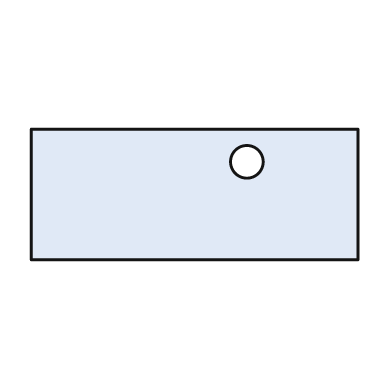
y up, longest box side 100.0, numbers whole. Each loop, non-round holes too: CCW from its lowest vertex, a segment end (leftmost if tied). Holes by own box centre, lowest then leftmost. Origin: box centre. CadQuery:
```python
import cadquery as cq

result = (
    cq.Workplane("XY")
    .moveTo(-50.0, -20.0)
    .lineTo(50.0, -20.0)
    .lineTo(50.0, 20.0)
    .lineTo(-50.0, 20.0)
    .close()
    .moveTo(16.0, 10.0)
    .circle(5.0)
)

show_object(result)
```